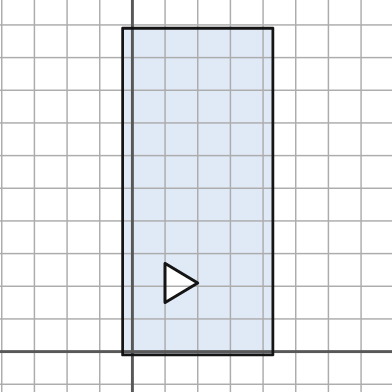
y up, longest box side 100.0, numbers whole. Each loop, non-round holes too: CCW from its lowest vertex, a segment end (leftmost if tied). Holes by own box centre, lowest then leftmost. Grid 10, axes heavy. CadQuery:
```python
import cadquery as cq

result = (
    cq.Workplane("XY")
    .moveTo(-3.0, -1.0)
    .lineTo(43.0, -1.0)
    .lineTo(43.0, 99.0)
    .lineTo(-3.0, 99.0)
    .close()
    .moveTo(10.0, 15.0)
    .lineTo(20.0, 21.0)
    .lineTo(10.0, 27.0)
    .close()
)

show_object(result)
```